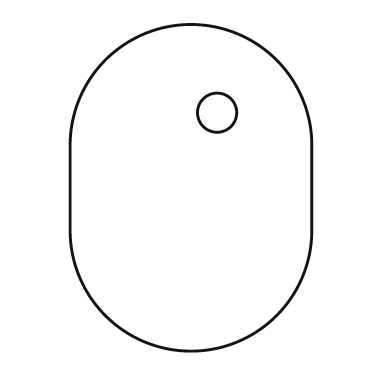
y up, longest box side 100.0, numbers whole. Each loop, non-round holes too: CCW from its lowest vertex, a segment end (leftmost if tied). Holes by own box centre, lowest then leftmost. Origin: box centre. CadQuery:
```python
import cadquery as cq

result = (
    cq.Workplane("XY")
    .moveTo(-37.0, -13.0)
    .threePointArc((0.0, -50.0), (37.0, -13.0))
    .lineTo(37.0, 13.0)
    .threePointArc((0.0, 50.0), (-37.0, 13.0))
    .close()
    .moveTo(8.0, 23.0)
    .circle(6.0)
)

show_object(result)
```